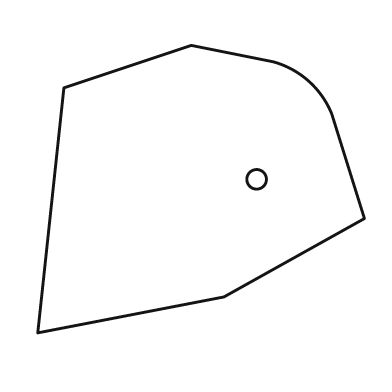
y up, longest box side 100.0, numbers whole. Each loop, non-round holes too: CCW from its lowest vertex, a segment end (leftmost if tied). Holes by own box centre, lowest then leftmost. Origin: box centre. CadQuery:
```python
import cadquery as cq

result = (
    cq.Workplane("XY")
    .moveTo(-50.0, -44.0)
    .lineTo(7.0, -33.0)
    .lineTo(50.0, -9.0)
    .lineTo(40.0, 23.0)
    .threePointArc((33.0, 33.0), (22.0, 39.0))
    .lineTo(-3.0, 44.0)
    .lineTo(-42.0, 31.0)
    .close()
    .moveTo(17.0, 3.0)
    .circle(3.0)
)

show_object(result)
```